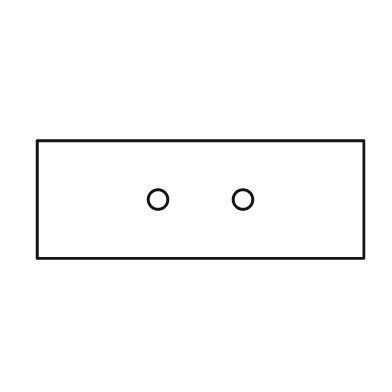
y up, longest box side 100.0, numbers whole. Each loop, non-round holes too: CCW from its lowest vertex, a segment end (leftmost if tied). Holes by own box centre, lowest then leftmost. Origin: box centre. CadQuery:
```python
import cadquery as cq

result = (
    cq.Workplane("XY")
    .moveTo(-50.0, -18.0)
    .lineTo(50.0, -18.0)
    .lineTo(50.0, 18.0)
    .lineTo(-50.0, 18.0)
    .close()
    .moveTo(-13.0, 0.0)
    .circle(3.0)
    .moveTo(13.0, 0.0)
    .circle(3.0)
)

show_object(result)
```